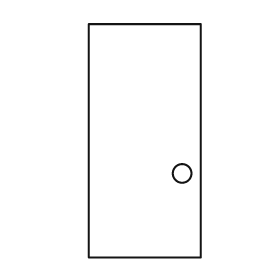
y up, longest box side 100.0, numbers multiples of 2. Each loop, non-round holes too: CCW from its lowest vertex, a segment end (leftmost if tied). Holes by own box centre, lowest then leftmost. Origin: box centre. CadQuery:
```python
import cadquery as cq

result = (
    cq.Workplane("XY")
    .moveTo(-24.0, -50.0)
    .lineTo(24.0, -50.0)
    .lineTo(24.0, 50.0)
    .lineTo(-24.0, 50.0)
    .close()
    .moveTo(16.0, -14.0)
    .circle(4.0)
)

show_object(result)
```